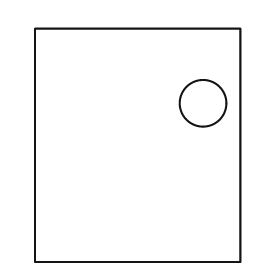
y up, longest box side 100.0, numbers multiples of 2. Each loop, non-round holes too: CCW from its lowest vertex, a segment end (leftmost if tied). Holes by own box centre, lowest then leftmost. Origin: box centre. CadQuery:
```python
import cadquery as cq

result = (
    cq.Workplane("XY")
    .moveTo(-44.0, -50.0)
    .lineTo(44.0, -50.0)
    .lineTo(44.0, 50.0)
    .lineTo(-44.0, 50.0)
    .close()
    .moveTo(28.0, 18.0)
    .circle(10.0)
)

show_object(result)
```